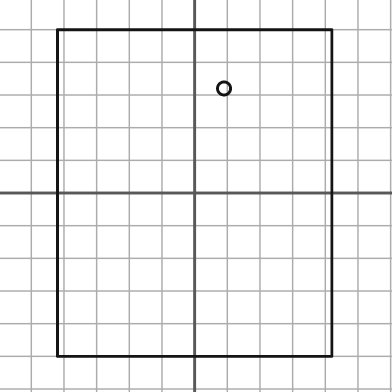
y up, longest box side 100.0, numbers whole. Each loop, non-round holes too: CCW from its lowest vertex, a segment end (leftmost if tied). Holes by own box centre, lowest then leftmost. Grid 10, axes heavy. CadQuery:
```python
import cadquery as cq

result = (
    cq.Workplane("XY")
    .moveTo(-42.0, -50.0)
    .lineTo(42.0, -50.0)
    .lineTo(42.0, 50.0)
    .lineTo(-42.0, 50.0)
    .close()
    .moveTo(9.0, 32.0)
    .circle(2.0)
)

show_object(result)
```